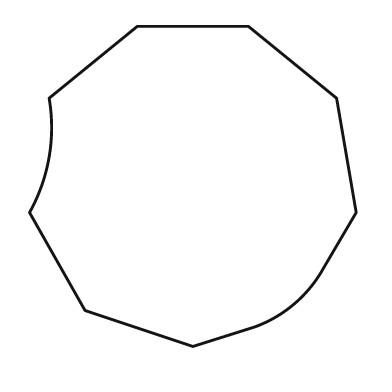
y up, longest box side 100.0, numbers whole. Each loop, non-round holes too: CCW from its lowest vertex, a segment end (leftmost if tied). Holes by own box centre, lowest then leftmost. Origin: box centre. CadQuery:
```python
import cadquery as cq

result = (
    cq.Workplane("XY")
    .moveTo(0.0, -49.0)
    .lineTo(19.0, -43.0)
    .threePointArc((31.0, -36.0), (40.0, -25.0))
    .lineTo(50.0, -8.0)
    .lineTo(44.0, 27.0)
    .lineTo(17.0, 49.0)
    .lineTo(-17.0, 49.0)
    .lineTo(-44.0, 27.0)
    .threePointArc((-44.0, 9.0), (-50.0, -8.0))
    .lineTo(-33.0, -38.0)
    .close()
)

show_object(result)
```